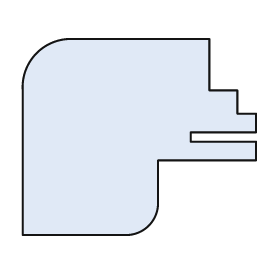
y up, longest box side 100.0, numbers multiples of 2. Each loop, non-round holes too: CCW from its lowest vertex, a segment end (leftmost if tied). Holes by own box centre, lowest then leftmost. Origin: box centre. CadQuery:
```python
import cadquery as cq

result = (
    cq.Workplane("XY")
    .moveTo(-50.0, -42.0)
    .lineTo(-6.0, -42.0)
    .threePointArc((4.0, -38.0), (8.0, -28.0))
    .lineTo(8.0, -10.0)
    .lineTo(50.0, -10.0)
    .lineTo(50.0, -2.0)
    .lineTo(22.0, -2.0)
    .lineTo(22.0, 2.0)
    .lineTo(50.0, 2.0)
    .lineTo(50.0, 10.0)
    .lineTo(42.0, 10.0)
    .lineTo(42.0, 20.0)
    .lineTo(30.0, 20.0)
    .lineTo(30.0, 42.0)
    .lineTo(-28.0, 42.0)
    .threePointArc((-44.0, 36.0), (-50.0, 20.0))
    .close()
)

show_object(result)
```